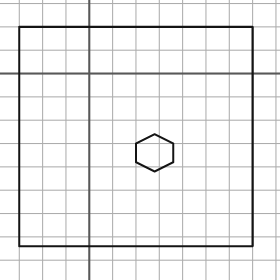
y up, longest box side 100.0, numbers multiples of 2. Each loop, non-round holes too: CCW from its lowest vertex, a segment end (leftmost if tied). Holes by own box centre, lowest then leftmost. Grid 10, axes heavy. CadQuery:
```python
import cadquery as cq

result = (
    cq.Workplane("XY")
    .moveTo(-30.0, -74.0)
    .lineTo(70.0, -74.0)
    .lineTo(70.0, 20.0)
    .lineTo(-30.0, 20.0)
    .close()
    .moveTo(28.0, -42.0)
    .lineTo(36.0, -38.0)
    .lineTo(36.0, -30.0)
    .lineTo(28.0, -26.0)
    .lineTo(20.0, -30.0)
    .lineTo(20.0, -38.0)
    .close()
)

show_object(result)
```